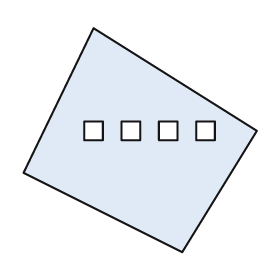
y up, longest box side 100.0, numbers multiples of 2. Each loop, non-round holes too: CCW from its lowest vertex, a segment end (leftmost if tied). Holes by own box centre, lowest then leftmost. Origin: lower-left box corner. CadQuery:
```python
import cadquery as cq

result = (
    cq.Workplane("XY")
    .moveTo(68.0, 0.0)
    .lineTo(100.0, 52.0)
    .lineTo(30.0, 96.0)
    .lineTo(0.0, 34.0)
    .close()
    .moveTo(26.0, 48.0)
    .lineTo(34.0, 48.0)
    .lineTo(34.0, 56.0)
    .lineTo(26.0, 56.0)
    .close()
    .moveTo(42.0, 48.0)
    .lineTo(50.0, 48.0)
    .lineTo(50.0, 56.0)
    .lineTo(42.0, 56.0)
    .close()
    .moveTo(58.0, 48.0)
    .lineTo(66.0, 48.0)
    .lineTo(66.0, 56.0)
    .lineTo(58.0, 56.0)
    .close()
    .moveTo(74.0, 48.0)
    .lineTo(82.0, 48.0)
    .lineTo(82.0, 56.0)
    .lineTo(74.0, 56.0)
    .close()
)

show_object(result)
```